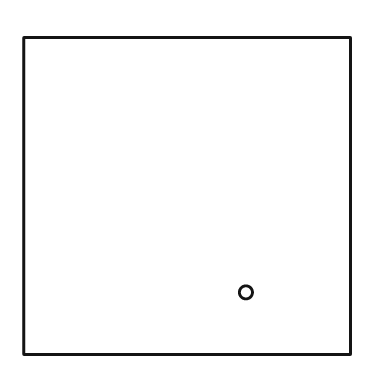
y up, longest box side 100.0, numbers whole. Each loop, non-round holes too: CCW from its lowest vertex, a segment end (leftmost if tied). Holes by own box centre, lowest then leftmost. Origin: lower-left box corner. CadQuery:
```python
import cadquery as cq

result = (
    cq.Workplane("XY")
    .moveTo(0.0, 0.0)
    .lineTo(100.0, 0.0)
    .lineTo(100.0, 97.0)
    .lineTo(0.0, 97.0)
    .close()
    .moveTo(68.0, 19.0)
    .circle(2.0)
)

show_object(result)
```